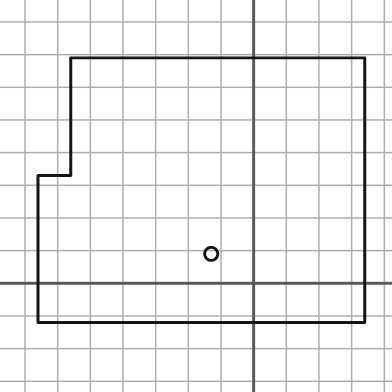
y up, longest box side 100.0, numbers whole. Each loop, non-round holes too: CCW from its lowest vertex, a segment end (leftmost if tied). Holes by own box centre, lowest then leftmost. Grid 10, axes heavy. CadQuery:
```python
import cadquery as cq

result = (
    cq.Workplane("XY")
    .moveTo(-66.0, -12.0)
    .lineTo(34.0, -12.0)
    .lineTo(34.0, 69.0)
    .lineTo(-56.0, 69.0)
    .lineTo(-56.0, 33.0)
    .lineTo(-66.0, 33.0)
    .close()
    .moveTo(-13.0, 9.0)
    .circle(2.0)
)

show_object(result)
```